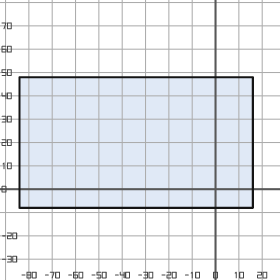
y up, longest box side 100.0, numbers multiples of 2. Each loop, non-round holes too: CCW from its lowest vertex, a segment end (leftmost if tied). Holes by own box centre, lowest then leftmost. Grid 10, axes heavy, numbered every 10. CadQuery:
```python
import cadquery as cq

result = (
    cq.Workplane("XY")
    .moveTo(-84.0, -8.0)
    .lineTo(16.0, -8.0)
    .lineTo(16.0, 48.0)
    .lineTo(-84.0, 48.0)
    .close()
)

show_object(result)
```